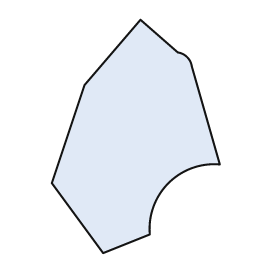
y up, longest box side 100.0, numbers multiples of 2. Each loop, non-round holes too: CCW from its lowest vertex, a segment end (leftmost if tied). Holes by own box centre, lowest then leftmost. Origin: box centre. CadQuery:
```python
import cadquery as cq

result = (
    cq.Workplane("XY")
    .moveTo(-14.0, -50.0)
    .lineTo(6.0, -42.0)
    .threePointArc((14.0, -20.0), (36.0, -12.0))
    .lineTo(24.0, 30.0)
    .threePointArc((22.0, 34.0), (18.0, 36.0))
    .lineTo(2.0, 50.0)
    .lineTo(-22.0, 22.0)
    .lineTo(-36.0, -20.0)
    .close()
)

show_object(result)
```